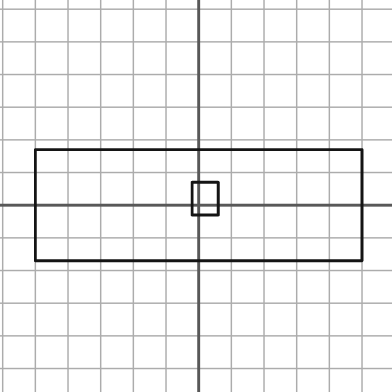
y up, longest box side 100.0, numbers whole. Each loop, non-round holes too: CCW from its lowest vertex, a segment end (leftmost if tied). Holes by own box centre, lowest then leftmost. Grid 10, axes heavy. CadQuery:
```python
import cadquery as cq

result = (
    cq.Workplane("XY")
    .moveTo(-50.0, -17.0)
    .lineTo(50.0, -17.0)
    .lineTo(50.0, 17.0)
    .lineTo(-50.0, 17.0)
    .close()
    .moveTo(-2.0, -3.0)
    .lineTo(6.0, -3.0)
    .lineTo(6.0, 7.0)
    .lineTo(-2.0, 7.0)
    .close()
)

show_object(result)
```